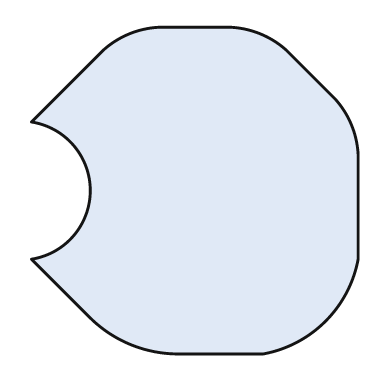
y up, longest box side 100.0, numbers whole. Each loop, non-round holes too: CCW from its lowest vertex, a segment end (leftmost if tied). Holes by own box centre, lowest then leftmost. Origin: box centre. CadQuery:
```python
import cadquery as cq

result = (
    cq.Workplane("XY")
    .moveTo(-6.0, -50.0)
    .lineTo(21.0, -50.0)
    .threePointArc((40.0, -40.0), (50.0, -21.0))
    .lineTo(50.0, 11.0)
    .threePointArc((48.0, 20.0), (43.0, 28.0))
    .lineTo(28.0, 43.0)
    .threePointArc((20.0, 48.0), (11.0, 50.0))
    .lineTo(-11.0, 50.0)
    .threePointArc((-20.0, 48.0), (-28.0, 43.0))
    .lineTo(-50.0, 21.0)
    .threePointArc((-32.0, 0.0), (-50.0, -21.0))
    .lineTo(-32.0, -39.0)
    .threePointArc((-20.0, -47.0), (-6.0, -50.0))
    .close()
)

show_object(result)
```